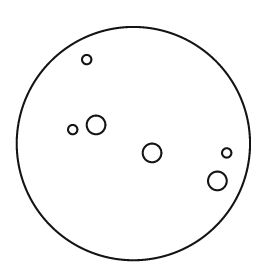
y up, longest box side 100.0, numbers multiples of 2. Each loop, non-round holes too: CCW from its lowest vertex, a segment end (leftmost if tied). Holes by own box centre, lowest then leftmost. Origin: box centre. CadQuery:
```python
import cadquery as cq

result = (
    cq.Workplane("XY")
    .moveTo(0.0, 0.0)
    .circle(50.0)
    .moveTo(36.0, -16.0)
    .circle(4.0)
    .moveTo(8.0, -4.0)
    .circle(4.0)
    .moveTo(40.0, -4.0)
    .circle(2.0)
    .moveTo(-26.0, 6.0)
    .circle(2.0)
    .moveTo(-16.0, 8.0)
    .circle(4.0)
    .moveTo(-20.0, 36.0)
    .circle(2.0)
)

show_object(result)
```